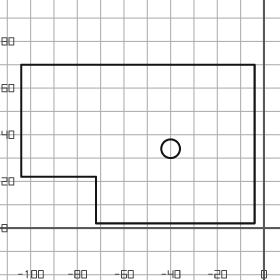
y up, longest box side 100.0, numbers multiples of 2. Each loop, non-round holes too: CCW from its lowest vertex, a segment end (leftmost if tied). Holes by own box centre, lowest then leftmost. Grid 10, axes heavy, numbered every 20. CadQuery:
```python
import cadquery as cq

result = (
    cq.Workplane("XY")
    .moveTo(-72.0, 2.0)
    .lineTo(-4.0, 2.0)
    .lineTo(-4.0, 70.0)
    .lineTo(-104.0, 70.0)
    .lineTo(-104.0, 22.0)
    .lineTo(-72.0, 22.0)
    .close()
    .moveTo(-40.0, 34.0)
    .circle(4.0)
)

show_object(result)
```